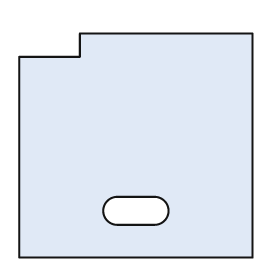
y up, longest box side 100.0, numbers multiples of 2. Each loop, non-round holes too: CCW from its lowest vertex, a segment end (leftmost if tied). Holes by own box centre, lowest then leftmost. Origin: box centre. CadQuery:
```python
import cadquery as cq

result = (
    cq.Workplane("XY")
    .moveTo(-50.0, -48.0)
    .lineTo(50.0, -48.0)
    .lineTo(50.0, 48.0)
    .lineTo(-24.0, 48.0)
    .lineTo(-24.0, 38.0)
    .lineTo(-50.0, 38.0)
    .close()
    .moveTo(-8.0, -34.0)
    .lineTo(8.0, -34.0)
    .threePointArc((14.0, -28.0), (8.0, -22.0))
    .lineTo(-8.0, -22.0)
    .threePointArc((-14.0, -28.0), (-8.0, -34.0))
    .close()
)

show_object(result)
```